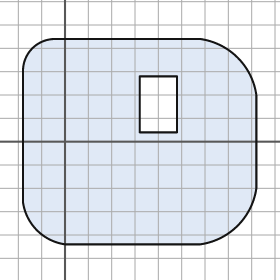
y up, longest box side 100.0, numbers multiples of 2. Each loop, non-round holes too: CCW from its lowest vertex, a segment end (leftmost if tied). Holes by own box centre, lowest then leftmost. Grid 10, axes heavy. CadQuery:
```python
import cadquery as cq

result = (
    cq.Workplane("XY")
    .moveTo(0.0, -44.0)
    .lineTo(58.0, -44.0)
    .threePointArc((74.0, -36.0), (82.0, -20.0))
    .lineTo(82.0, 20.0)
    .threePointArc((74.0, 36.0), (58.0, 44.0))
    .lineTo(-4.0, 44.0)
    .threePointArc((-14.0, 40.0), (-18.0, 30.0))
    .lineTo(-18.0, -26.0)
    .threePointArc((-12.0, -38.0), (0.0, -44.0))
    .close()
    .moveTo(32.0, 4.0)
    .lineTo(48.0, 4.0)
    .lineTo(48.0, 28.0)
    .lineTo(32.0, 28.0)
    .close()
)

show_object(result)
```